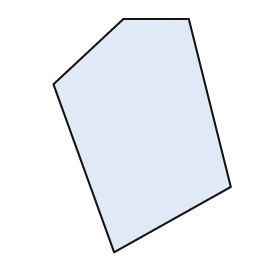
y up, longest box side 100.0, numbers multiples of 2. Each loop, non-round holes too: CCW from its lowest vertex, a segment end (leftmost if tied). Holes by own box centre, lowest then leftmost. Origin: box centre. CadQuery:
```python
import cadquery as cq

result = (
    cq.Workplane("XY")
    .moveTo(-12.0, -50.0)
    .lineTo(38.0, -22.0)
    .lineTo(20.0, 50.0)
    .lineTo(-8.0, 50.0)
    .lineTo(-38.0, 22.0)
    .close()
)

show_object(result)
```